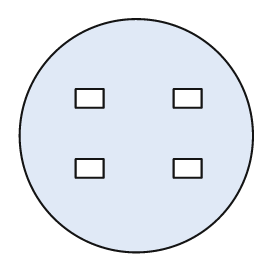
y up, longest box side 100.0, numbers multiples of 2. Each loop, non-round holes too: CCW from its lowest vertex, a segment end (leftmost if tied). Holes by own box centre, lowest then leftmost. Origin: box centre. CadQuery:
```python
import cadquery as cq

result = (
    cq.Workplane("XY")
    .moveTo(0.0, 0.0)
    .circle(50.0)
    .moveTo(-26.0, -18.0)
    .lineTo(-14.0, -18.0)
    .lineTo(-14.0, -10.0)
    .lineTo(-26.0, -10.0)
    .close()
    .moveTo(16.0, -18.0)
    .lineTo(28.0, -18.0)
    .lineTo(28.0, -10.0)
    .lineTo(16.0, -10.0)
    .close()
    .moveTo(-26.0, 12.0)
    .lineTo(-14.0, 12.0)
    .lineTo(-14.0, 20.0)
    .lineTo(-26.0, 20.0)
    .close()
    .moveTo(16.0, 12.0)
    .lineTo(28.0, 12.0)
    .lineTo(28.0, 20.0)
    .lineTo(16.0, 20.0)
    .close()
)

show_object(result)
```